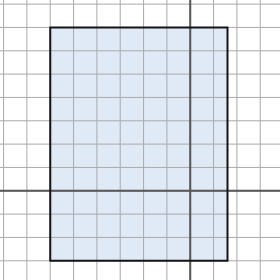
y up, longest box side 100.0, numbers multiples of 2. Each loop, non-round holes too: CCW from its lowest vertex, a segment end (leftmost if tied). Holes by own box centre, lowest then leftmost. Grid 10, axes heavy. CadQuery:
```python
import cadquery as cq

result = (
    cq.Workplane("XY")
    .moveTo(-60.0, -30.0)
    .lineTo(16.0, -30.0)
    .lineTo(16.0, 70.0)
    .lineTo(-60.0, 70.0)
    .close()
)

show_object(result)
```